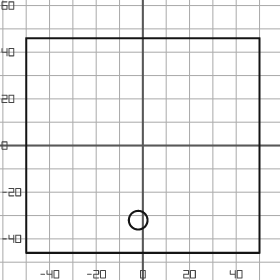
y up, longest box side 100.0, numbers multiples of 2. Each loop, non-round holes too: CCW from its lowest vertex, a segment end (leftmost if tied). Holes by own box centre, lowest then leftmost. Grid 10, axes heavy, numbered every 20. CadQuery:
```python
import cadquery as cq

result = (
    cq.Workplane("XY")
    .moveTo(-50.0, -46.0)
    .lineTo(50.0, -46.0)
    .lineTo(50.0, 46.0)
    .lineTo(-50.0, 46.0)
    .close()
    .moveTo(-2.0, -32.0)
    .circle(4.0)
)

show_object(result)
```